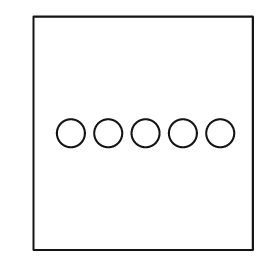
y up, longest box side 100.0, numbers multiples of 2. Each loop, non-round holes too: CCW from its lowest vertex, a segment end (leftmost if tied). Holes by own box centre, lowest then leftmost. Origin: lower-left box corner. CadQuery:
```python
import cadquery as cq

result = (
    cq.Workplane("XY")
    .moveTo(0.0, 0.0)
    .lineTo(94.0, 0.0)
    .lineTo(94.0, 100.0)
    .lineTo(0.0, 100.0)
    .close()
    .moveTo(16.0, 50.0)
    .circle(6.0)
    .moveTo(32.0, 50.0)
    .circle(6.0)
    .moveTo(48.0, 50.0)
    .circle(6.0)
    .moveTo(64.0, 50.0)
    .circle(6.0)
    .moveTo(80.0, 50.0)
    .circle(6.0)
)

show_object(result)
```